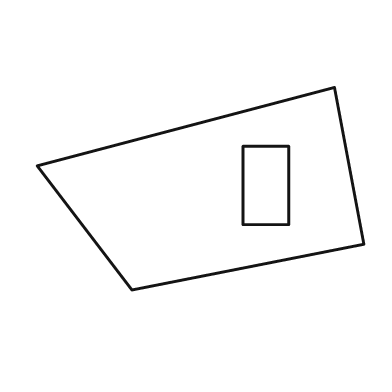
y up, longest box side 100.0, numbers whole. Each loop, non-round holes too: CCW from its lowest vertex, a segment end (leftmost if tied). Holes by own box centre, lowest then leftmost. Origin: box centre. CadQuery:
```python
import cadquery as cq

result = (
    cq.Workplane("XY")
    .moveTo(-21.0, -31.0)
    .lineTo(50.0, -17.0)
    .lineTo(41.0, 31.0)
    .lineTo(-50.0, 7.0)
    .close()
    .moveTo(13.0, -11.0)
    .lineTo(27.0, -11.0)
    .lineTo(27.0, 13.0)
    .lineTo(13.0, 13.0)
    .close()
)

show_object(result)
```